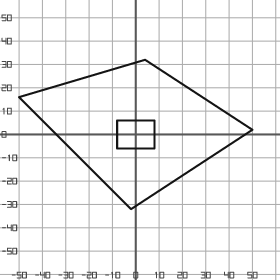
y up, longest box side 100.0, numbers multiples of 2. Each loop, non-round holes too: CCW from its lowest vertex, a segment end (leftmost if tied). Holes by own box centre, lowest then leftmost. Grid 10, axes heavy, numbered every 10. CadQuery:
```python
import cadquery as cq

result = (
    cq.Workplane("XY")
    .moveTo(-2.0, -32.0)
    .lineTo(50.0, 2.0)
    .lineTo(4.0, 32.0)
    .lineTo(-50.0, 16.0)
    .close()
    .moveTo(-8.0, -6.0)
    .lineTo(8.0, -6.0)
    .lineTo(8.0, 6.0)
    .lineTo(-8.0, 6.0)
    .close()
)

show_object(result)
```